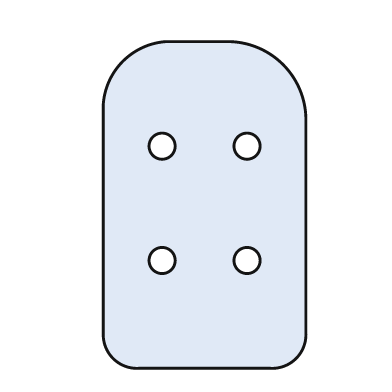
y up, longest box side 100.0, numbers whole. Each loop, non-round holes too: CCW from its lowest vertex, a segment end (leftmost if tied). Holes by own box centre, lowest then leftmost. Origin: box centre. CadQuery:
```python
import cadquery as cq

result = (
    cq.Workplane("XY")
    .moveTo(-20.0, -50.0)
    .lineTo(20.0, -50.0)
    .threePointArc((28.0, -47.0), (31.0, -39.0))
    .lineTo(31.0, 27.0)
    .threePointArc((24.0, 43.0), (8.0, 50.0))
    .lineTo(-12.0, 50.0)
    .threePointArc((-25.0, 44.0), (-31.0, 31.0))
    .lineTo(-31.0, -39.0)
    .threePointArc((-28.0, -47.0), (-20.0, -50.0))
    .close()
    .moveTo(-13.0, -17.0)
    .circle(4.0)
    .moveTo(13.0, -17.0)
    .circle(4.0)
    .moveTo(-13.0, 18.0)
    .circle(4.0)
    .moveTo(13.0, 18.0)
    .circle(4.0)
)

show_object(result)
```